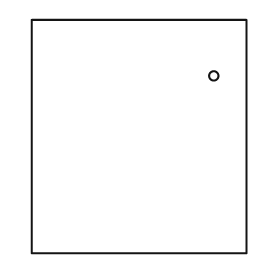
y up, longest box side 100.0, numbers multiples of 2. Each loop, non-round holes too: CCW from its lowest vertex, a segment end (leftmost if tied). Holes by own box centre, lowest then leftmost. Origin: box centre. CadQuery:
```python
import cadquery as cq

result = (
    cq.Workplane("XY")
    .moveTo(-46.0, -50.0)
    .lineTo(46.0, -50.0)
    .lineTo(46.0, 50.0)
    .lineTo(-46.0, 50.0)
    .close()
    .moveTo(32.0, 26.0)
    .circle(2.0)
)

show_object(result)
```